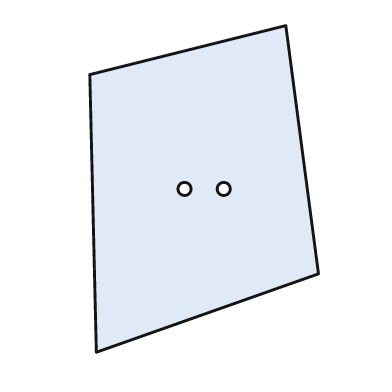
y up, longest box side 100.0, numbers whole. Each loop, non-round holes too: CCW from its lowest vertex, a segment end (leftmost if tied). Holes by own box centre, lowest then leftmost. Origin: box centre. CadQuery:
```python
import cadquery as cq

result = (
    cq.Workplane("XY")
    .moveTo(-33.0, -50.0)
    .lineTo(35.0, -26.0)
    .lineTo(25.0, 50.0)
    .lineTo(-35.0, 35.0)
    .close()
    .moveTo(-6.0, 0.0)
    .circle(2.0)
    .moveTo(6.0, 0.0)
    .circle(2.0)
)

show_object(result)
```